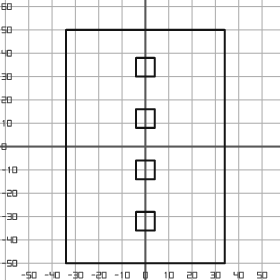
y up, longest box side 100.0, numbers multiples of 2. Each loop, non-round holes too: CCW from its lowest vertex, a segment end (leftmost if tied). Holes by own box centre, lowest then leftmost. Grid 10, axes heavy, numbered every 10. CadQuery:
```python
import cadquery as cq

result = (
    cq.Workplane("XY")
    .moveTo(-34.0, -50.0)
    .lineTo(34.0, -50.0)
    .lineTo(34.0, 50.0)
    .lineTo(-34.0, 50.0)
    .close()
    .moveTo(-4.0, -36.0)
    .lineTo(4.0, -36.0)
    .lineTo(4.0, -28.0)
    .lineTo(-4.0, -28.0)
    .close()
    .moveTo(-4.0, -14.0)
    .lineTo(4.0, -14.0)
    .lineTo(4.0, -6.0)
    .lineTo(-4.0, -6.0)
    .close()
    .moveTo(-4.0, 8.0)
    .lineTo(4.0, 8.0)
    .lineTo(4.0, 16.0)
    .lineTo(-4.0, 16.0)
    .close()
    .moveTo(-4.0, 30.0)
    .lineTo(4.0, 30.0)
    .lineTo(4.0, 38.0)
    .lineTo(-4.0, 38.0)
    .close()
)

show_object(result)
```